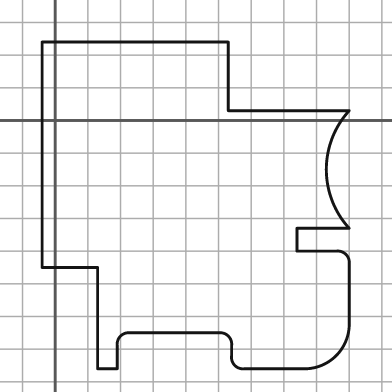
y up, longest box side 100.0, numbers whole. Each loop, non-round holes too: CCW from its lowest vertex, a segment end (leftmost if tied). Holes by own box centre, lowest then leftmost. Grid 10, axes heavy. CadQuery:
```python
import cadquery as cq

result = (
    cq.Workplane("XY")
    .moveTo(13.0, -76.0)
    .lineTo(19.0, -76.0)
    .lineTo(19.0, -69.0)
    .threePointArc((20.0, -66.0), (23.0, -65.0))
    .lineTo(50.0, -65.0)
    .threePointArc((53.0, -66.0), (54.0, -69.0))
    .lineTo(54.0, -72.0)
    .threePointArc((55.0, -75.0), (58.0, -76.0))
    .lineTo(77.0, -76.0)
    .threePointArc((86.0, -72.0), (90.0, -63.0))
    .lineTo(90.0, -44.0)
    .threePointArc((89.0, -41.0), (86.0, -40.0))
    .lineTo(74.0, -40.0)
    .lineTo(74.0, -33.0)
    .lineTo(90.0, -33.0)
    .threePointArc((83.0, -15.0), (90.0, 3.0))
    .lineTo(53.0, 3.0)
    .lineTo(53.0, 24.0)
    .lineTo(-4.0, 24.0)
    .lineTo(-4.0, -45.0)
    .lineTo(13.0, -45.0)
    .close()
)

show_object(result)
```